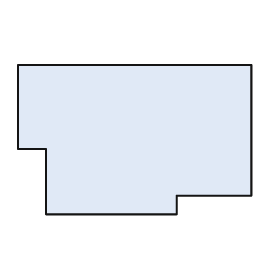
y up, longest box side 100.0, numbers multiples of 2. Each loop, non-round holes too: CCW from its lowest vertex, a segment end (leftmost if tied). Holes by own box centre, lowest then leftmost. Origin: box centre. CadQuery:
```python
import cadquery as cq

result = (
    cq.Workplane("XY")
    .moveTo(-38.0, -32.0)
    .lineTo(18.0, -32.0)
    .lineTo(18.0, -24.0)
    .lineTo(50.0, -24.0)
    .lineTo(50.0, 32.0)
    .lineTo(-50.0, 32.0)
    .lineTo(-50.0, -4.0)
    .lineTo(-38.0, -4.0)
    .close()
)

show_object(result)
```